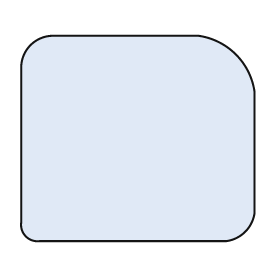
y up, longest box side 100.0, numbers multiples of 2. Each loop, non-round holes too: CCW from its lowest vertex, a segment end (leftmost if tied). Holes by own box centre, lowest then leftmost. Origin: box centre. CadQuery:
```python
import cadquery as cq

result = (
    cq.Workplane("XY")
    .moveTo(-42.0, -44.0)
    .lineTo(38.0, -44.0)
    .threePointArc((46.0, -40.0), (50.0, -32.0))
    .lineTo(50.0, 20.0)
    .threePointArc((42.0, 36.0), (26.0, 44.0))
    .lineTo(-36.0, 44.0)
    .threePointArc((-46.0, 40.0), (-50.0, 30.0))
    .lineTo(-50.0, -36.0)
    .threePointArc((-48.0, -42.0), (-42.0, -44.0))
    .close()
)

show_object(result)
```